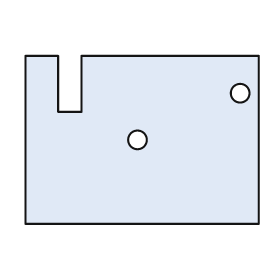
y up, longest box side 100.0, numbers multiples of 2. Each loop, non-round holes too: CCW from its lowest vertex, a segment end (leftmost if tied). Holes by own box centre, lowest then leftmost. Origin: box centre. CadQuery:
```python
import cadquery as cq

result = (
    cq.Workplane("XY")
    .moveTo(-50.0, -36.0)
    .lineTo(50.0, -36.0)
    .lineTo(50.0, 36.0)
    .lineTo(-26.0, 36.0)
    .lineTo(-26.0, 12.0)
    .lineTo(-36.0, 12.0)
    .lineTo(-36.0, 36.0)
    .lineTo(-50.0, 36.0)
    .close()
    .moveTo(-2.0, 0.0)
    .circle(4.0)
    .moveTo(42.0, 20.0)
    .circle(4.0)
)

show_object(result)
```